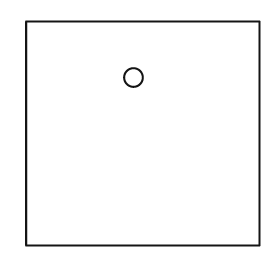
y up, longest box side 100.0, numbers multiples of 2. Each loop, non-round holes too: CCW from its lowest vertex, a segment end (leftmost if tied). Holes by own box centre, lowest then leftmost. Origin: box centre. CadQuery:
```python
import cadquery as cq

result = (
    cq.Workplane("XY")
    .moveTo(-50.0, -48.0)
    .lineTo(50.0, -48.0)
    .lineTo(50.0, 48.0)
    .lineTo(-50.0, 48.0)
    .close()
    .moveTo(-4.0, 24.0)
    .circle(4.0)
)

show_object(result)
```